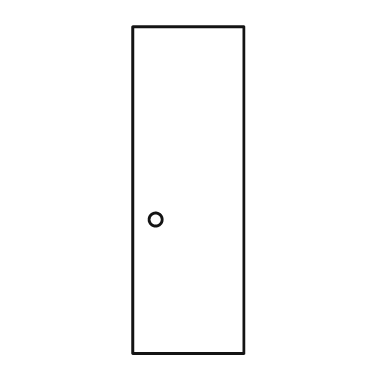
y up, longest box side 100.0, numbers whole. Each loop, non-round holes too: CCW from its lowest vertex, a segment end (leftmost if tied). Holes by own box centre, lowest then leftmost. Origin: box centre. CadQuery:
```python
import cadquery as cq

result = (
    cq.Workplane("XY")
    .moveTo(-17.0, -50.0)
    .lineTo(17.0, -50.0)
    .lineTo(17.0, 50.0)
    .lineTo(-17.0, 50.0)
    .close()
    .moveTo(-10.0, -9.0)
    .circle(2.0)
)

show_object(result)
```